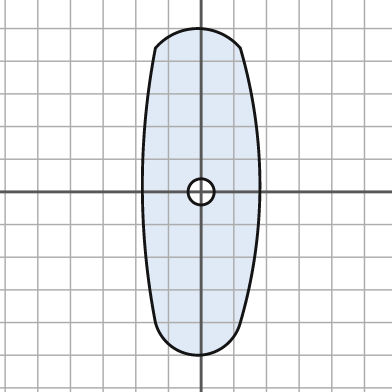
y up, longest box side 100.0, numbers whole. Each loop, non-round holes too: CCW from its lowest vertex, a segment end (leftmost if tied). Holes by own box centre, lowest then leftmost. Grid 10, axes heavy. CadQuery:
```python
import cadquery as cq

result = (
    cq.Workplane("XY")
    .moveTo(-14.0, -40.0)
    .threePointArc((-1.0, -50.0), (12.0, -40.0))
    .threePointArc((18.0, 2.0), (12.0, 44.0))
    .threePointArc((-1.0, 50.0), (-14.0, 44.0))
    .threePointArc((-18.0, 2.0), (-14.0, -40.0))
    .close()
    .moveTo(0.0, 0.0)
    .circle(4.0)
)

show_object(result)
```